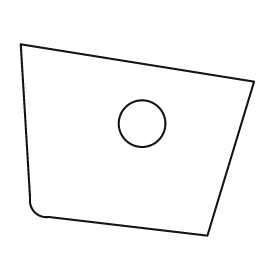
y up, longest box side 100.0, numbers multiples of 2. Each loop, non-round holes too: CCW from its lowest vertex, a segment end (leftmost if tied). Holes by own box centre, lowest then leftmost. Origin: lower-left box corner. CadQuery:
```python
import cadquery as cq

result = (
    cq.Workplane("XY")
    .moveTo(80.0, 0.0)
    .lineTo(100.0, 66.0)
    .lineTo(0.0, 82.0)
    .lineTo(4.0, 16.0)
    .threePointArc((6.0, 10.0), (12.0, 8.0))
    .close()
    .moveTo(52.0, 48.0)
    .circle(10.0)
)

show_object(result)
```